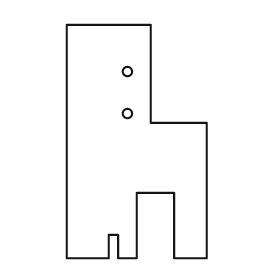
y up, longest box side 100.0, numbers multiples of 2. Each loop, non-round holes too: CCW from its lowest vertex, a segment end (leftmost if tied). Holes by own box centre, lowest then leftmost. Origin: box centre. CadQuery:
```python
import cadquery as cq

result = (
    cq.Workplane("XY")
    .moveTo(-30.0, -50.0)
    .lineTo(-12.0, -50.0)
    .lineTo(-12.0, -40.0)
    .lineTo(-8.0, -40.0)
    .lineTo(-8.0, -50.0)
    .lineTo(0.0, -50.0)
    .lineTo(0.0, -22.0)
    .lineTo(16.0, -22.0)
    .lineTo(16.0, -50.0)
    .lineTo(30.0, -50.0)
    .lineTo(30.0, 8.0)
    .lineTo(6.0, 8.0)
    .lineTo(6.0, 50.0)
    .lineTo(-30.0, 50.0)
    .close()
    .moveTo(-4.0, 12.0)
    .circle(2.0)
    .moveTo(-4.0, 30.0)
    .circle(2.0)
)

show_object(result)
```